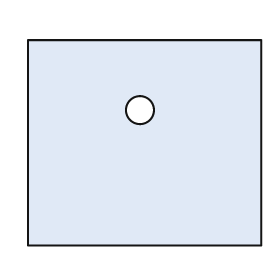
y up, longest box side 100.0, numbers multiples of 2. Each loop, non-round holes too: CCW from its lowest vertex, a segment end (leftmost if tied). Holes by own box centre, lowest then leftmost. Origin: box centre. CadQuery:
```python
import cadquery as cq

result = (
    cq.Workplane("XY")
    .moveTo(-50.0, -44.0)
    .lineTo(50.0, -44.0)
    .lineTo(50.0, 44.0)
    .lineTo(-50.0, 44.0)
    .close()
    .moveTo(-2.0, 14.0)
    .circle(6.0)
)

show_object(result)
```